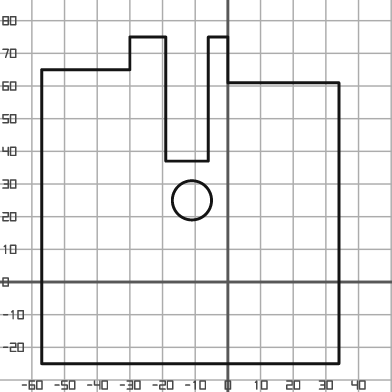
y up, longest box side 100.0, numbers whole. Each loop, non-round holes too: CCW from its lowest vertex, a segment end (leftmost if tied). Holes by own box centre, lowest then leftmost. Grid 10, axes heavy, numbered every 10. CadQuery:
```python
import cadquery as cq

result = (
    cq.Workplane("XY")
    .moveTo(-57.0, -25.0)
    .lineTo(34.0, -25.0)
    .lineTo(34.0, 61.0)
    .lineTo(0.0, 61.0)
    .lineTo(0.0, 75.0)
    .lineTo(-6.0, 75.0)
    .lineTo(-6.0, 37.0)
    .lineTo(-19.0, 37.0)
    .lineTo(-19.0, 75.0)
    .lineTo(-30.0, 75.0)
    .lineTo(-30.0, 65.0)
    .lineTo(-57.0, 65.0)
    .close()
    .moveTo(-11.0, 25.0)
    .circle(6.0)
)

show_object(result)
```